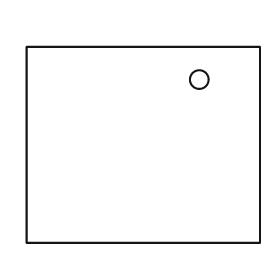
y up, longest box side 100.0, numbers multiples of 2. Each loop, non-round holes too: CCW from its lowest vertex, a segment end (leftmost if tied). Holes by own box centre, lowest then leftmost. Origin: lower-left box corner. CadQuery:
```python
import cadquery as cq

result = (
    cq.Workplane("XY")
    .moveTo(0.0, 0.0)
    .lineTo(100.0, 0.0)
    .lineTo(100.0, 84.0)
    .lineTo(0.0, 84.0)
    .close()
    .moveTo(74.0, 70.0)
    .circle(4.0)
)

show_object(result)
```